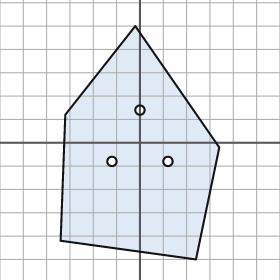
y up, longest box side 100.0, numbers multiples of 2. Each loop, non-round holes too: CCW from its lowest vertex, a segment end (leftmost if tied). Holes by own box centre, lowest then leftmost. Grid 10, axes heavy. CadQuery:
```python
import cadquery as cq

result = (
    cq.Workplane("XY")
    .moveTo(24.0, -50.0)
    .lineTo(34.0, -2.0)
    .lineTo(-2.0, 50.0)
    .lineTo(-32.0, 12.0)
    .lineTo(-34.0, -42.0)
    .close()
    .moveTo(-12.0, -8.0)
    .circle(2.0)
    .moveTo(12.0, -8.0)
    .circle(2.0)
    .moveTo(0.0, 14.0)
    .circle(2.0)
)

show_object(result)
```